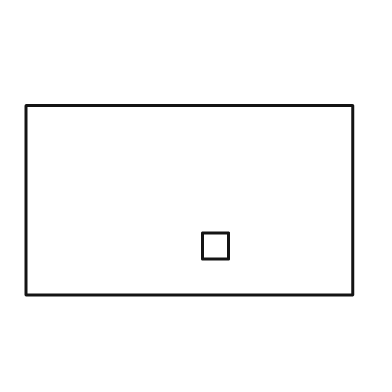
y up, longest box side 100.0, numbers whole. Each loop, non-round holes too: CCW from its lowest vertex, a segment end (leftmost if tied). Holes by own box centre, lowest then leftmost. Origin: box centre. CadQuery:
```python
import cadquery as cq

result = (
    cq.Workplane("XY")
    .moveTo(-50.0, -29.0)
    .lineTo(50.0, -29.0)
    .lineTo(50.0, 29.0)
    .lineTo(-50.0, 29.0)
    .close()
    .moveTo(4.0, -18.0)
    .lineTo(12.0, -18.0)
    .lineTo(12.0, -10.0)
    .lineTo(4.0, -10.0)
    .close()
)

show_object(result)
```